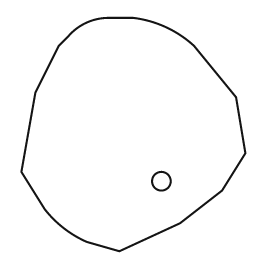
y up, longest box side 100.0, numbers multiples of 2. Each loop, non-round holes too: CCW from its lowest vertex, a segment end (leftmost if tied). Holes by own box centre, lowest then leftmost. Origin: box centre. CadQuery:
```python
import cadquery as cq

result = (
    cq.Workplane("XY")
    .moveTo(-6.0, -50.0)
    .lineTo(20.0, -38.0)
    .lineTo(38.0, -24.0)
    .lineTo(48.0, -8.0)
    .lineTo(44.0, 16.0)
    .lineTo(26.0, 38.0)
    .threePointArc((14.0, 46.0), (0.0, 50.0))
    .lineTo(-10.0, 50.0)
    .threePointArc((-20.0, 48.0), (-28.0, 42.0))
    .lineTo(-32.0, 38.0)
    .lineTo(-42.0, 18.0)
    .lineTo(-48.0, -16.0)
    .lineTo(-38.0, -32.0)
    .threePointArc((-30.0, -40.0), (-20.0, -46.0))
    .close()
    .moveTo(12.0, -20.0)
    .circle(4.0)
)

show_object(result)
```